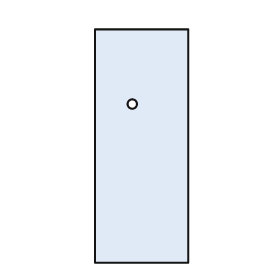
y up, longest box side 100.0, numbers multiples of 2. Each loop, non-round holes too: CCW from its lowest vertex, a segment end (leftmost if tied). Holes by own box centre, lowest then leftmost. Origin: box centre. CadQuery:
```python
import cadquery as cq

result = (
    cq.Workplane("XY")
    .moveTo(-20.0, -50.0)
    .lineTo(20.0, -50.0)
    .lineTo(20.0, 50.0)
    .lineTo(-20.0, 50.0)
    .close()
    .moveTo(-4.0, 18.0)
    .circle(2.0)
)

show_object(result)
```